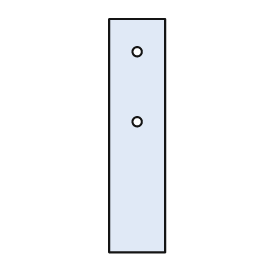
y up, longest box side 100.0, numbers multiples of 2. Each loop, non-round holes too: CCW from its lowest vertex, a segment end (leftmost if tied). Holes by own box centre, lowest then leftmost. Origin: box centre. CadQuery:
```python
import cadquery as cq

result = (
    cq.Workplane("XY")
    .moveTo(-12.0, -50.0)
    .lineTo(12.0, -50.0)
    .lineTo(12.0, 50.0)
    .lineTo(-12.0, 50.0)
    .close()
    .moveTo(0.0, 6.0)
    .circle(2.0)
    .moveTo(0.0, 36.0)
    .circle(2.0)
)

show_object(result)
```